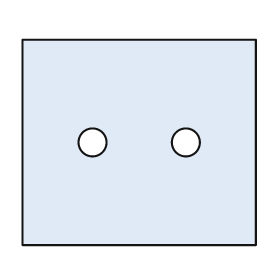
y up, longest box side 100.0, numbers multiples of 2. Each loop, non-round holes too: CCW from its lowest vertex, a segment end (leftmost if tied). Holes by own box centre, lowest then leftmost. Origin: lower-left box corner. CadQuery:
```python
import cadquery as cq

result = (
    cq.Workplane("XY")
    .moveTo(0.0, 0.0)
    .lineTo(100.0, 0.0)
    .lineTo(100.0, 88.0)
    .lineTo(0.0, 88.0)
    .close()
    .moveTo(30.0, 44.0)
    .circle(6.0)
    .moveTo(70.0, 44.0)
    .circle(6.0)
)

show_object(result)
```